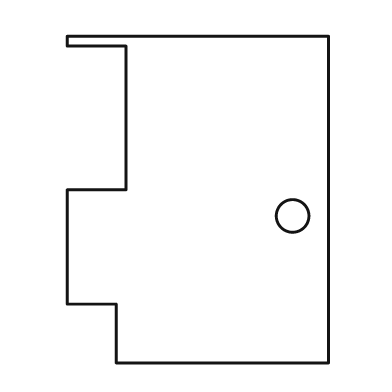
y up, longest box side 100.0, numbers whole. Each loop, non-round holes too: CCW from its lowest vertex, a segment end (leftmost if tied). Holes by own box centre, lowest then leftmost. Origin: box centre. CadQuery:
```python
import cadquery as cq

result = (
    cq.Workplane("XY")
    .moveTo(-25.0, -50.0)
    .lineTo(40.0, -50.0)
    .lineTo(40.0, 50.0)
    .lineTo(-40.0, 50.0)
    .lineTo(-40.0, 47.0)
    .lineTo(-22.0, 47.0)
    .lineTo(-22.0, 3.0)
    .lineTo(-40.0, 3.0)
    .lineTo(-40.0, -32.0)
    .lineTo(-25.0, -32.0)
    .close()
    .moveTo(29.0, -5.0)
    .circle(5.0)
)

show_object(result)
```